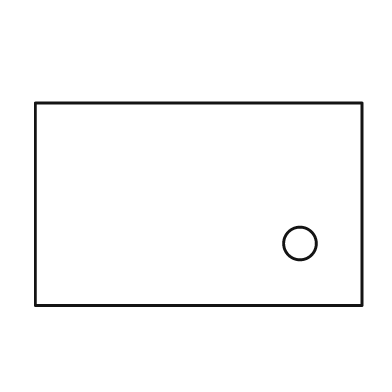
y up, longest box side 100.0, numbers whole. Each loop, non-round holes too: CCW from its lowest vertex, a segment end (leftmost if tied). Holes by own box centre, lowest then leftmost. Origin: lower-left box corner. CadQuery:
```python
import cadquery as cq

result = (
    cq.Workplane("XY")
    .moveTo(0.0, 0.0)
    .lineTo(100.0, 0.0)
    .lineTo(100.0, 62.0)
    .lineTo(0.0, 62.0)
    .close()
    .moveTo(81.0, 19.0)
    .circle(5.0)
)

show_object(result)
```